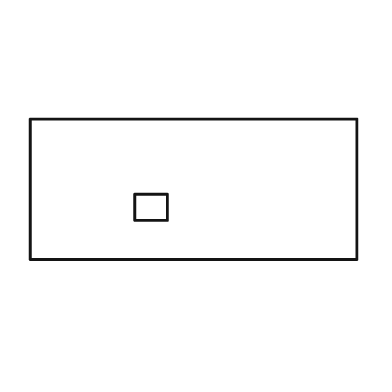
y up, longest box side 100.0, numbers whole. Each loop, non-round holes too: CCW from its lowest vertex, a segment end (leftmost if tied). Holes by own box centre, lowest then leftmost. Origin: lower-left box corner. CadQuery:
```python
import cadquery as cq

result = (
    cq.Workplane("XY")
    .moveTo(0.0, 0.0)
    .lineTo(100.0, 0.0)
    .lineTo(100.0, 43.0)
    .lineTo(0.0, 43.0)
    .close()
    .moveTo(32.0, 12.0)
    .lineTo(42.0, 12.0)
    .lineTo(42.0, 20.0)
    .lineTo(32.0, 20.0)
    .close()
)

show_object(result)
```